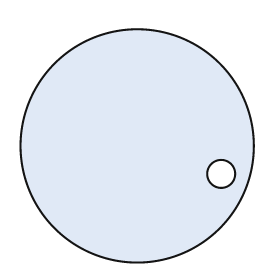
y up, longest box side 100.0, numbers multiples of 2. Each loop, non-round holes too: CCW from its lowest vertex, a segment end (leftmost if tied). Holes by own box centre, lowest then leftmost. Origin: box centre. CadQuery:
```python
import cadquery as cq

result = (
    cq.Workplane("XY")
    .moveTo(0.0, 0.0)
    .circle(50.0)
    .moveTo(36.0, -12.0)
    .circle(6.0)
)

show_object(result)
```